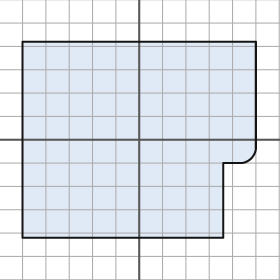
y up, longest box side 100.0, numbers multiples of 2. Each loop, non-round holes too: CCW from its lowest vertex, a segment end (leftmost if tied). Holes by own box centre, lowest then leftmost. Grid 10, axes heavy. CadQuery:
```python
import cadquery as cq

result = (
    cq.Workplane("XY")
    .moveTo(-50.0, -42.0)
    .lineTo(36.0, -42.0)
    .lineTo(36.0, -10.0)
    .lineTo(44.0, -10.0)
    .threePointArc((48.0, -8.0), (50.0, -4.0))
    .lineTo(50.0, 42.0)
    .lineTo(-50.0, 42.0)
    .close()
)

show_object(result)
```